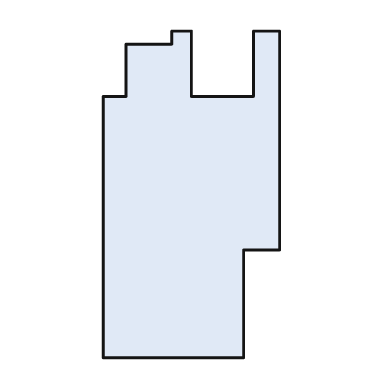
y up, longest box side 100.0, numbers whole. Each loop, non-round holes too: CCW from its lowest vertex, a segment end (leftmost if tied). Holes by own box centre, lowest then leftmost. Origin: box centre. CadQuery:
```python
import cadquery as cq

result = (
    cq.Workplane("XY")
    .moveTo(-27.0, -50.0)
    .lineTo(16.0, -50.0)
    .lineTo(16.0, -17.0)
    .lineTo(27.0, -17.0)
    .lineTo(27.0, 50.0)
    .lineTo(19.0, 50.0)
    .lineTo(19.0, 30.0)
    .lineTo(0.0, 30.0)
    .lineTo(0.0, 50.0)
    .lineTo(-6.0, 50.0)
    .lineTo(-6.0, 46.0)
    .lineTo(-20.0, 46.0)
    .lineTo(-20.0, 30.0)
    .lineTo(-27.0, 30.0)
    .close()
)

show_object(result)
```